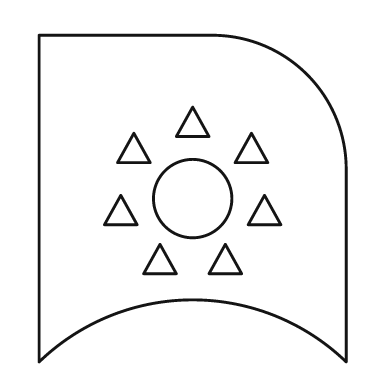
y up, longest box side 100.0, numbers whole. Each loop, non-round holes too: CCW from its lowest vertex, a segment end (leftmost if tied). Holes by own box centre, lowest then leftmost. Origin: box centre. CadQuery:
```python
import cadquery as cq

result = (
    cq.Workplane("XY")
    .moveTo(-47.0, -50.0)
    .threePointArc((0.0, -31.0), (47.0, -50.0))
    .lineTo(47.0, 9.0)
    .threePointArc((35.0, 38.0), (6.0, 50.0))
    .lineTo(-47.0, 50.0)
    .close()
    .moveTo(-15.0, -23.0)
    .lineTo(-5.0, -23.0)
    .lineTo(-10.0, -14.0)
    .close()
    .moveTo(5.0, -23.0)
    .lineTo(15.0, -23.0)
    .lineTo(10.0, -14.0)
    .close()
    .moveTo(-27.0, -8.0)
    .lineTo(-17.0, -8.0)
    .lineTo(-22.0, 1.0)
    .close()
    .moveTo(17.0, -8.0)
    .lineTo(27.0, -8.0)
    .lineTo(22.0, 1.0)
    .close()
    .moveTo(0.0, 0.0)
    .circle(12.0)
    .moveTo(-23.0, 11.0)
    .lineTo(-13.0, 11.0)
    .lineTo(-18.0, 20.0)
    .close()
    .moveTo(13.0, 11.0)
    .lineTo(23.0, 11.0)
    .lineTo(18.0, 20.0)
    .close()
    .moveTo(-5.0, 19.0)
    .lineTo(5.0, 19.0)
    .lineTo(0.0, 28.0)
    .close()
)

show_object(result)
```